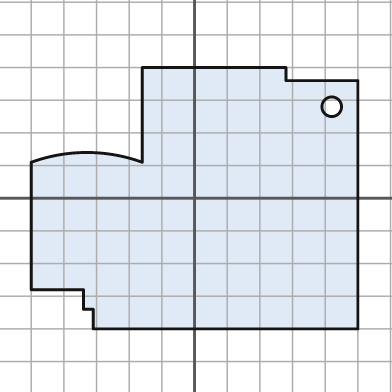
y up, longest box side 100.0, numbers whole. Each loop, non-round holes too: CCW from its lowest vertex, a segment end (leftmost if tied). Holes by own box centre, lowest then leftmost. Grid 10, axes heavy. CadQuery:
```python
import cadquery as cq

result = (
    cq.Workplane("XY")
    .moveTo(-31.0, -40.0)
    .lineTo(50.0, -40.0)
    .lineTo(50.0, 36.0)
    .lineTo(28.0, 36.0)
    .lineTo(28.0, 40.0)
    .lineTo(-16.0, 40.0)
    .lineTo(-16.0, 11.0)
    .threePointArc((-33.0, 14.0), (-50.0, 11.0))
    .lineTo(-50.0, -28.0)
    .lineTo(-34.0, -28.0)
    .lineTo(-34.0, -34.0)
    .lineTo(-31.0, -34.0)
    .close()
    .moveTo(42.0, 28.0)
    .circle(3.0)
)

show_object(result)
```